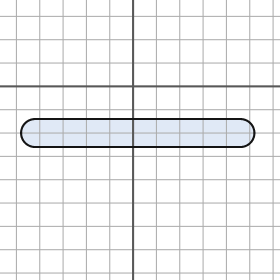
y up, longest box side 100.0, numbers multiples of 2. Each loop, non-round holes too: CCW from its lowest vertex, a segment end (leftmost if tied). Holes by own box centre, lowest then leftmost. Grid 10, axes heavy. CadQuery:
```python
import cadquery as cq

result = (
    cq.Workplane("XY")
    .moveTo(-42.0, -26.0)
    .lineTo(46.0, -26.0)
    .threePointArc((52.0, -20.0), (46.0, -14.0))
    .lineTo(-42.0, -14.0)
    .threePointArc((-48.0, -20.0), (-42.0, -26.0))
    .close()
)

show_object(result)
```